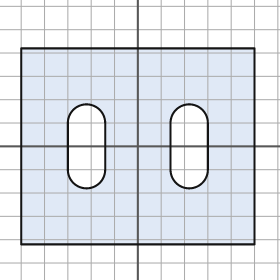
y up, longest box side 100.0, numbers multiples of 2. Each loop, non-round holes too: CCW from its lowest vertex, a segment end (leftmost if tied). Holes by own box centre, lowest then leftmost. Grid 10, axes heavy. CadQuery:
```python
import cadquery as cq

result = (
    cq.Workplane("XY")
    .moveTo(-50.0, -42.0)
    .lineTo(50.0, -42.0)
    .lineTo(50.0, 42.0)
    .lineTo(-50.0, 42.0)
    .close()
    .moveTo(-30.0, -10.0)
    .threePointArc((-22.0, -18.0), (-14.0, -10.0))
    .lineTo(-14.0, 10.0)
    .threePointArc((-22.0, 18.0), (-30.0, 10.0))
    .close()
    .moveTo(14.0, -10.0)
    .threePointArc((22.0, -18.0), (30.0, -10.0))
    .lineTo(30.0, 10.0)
    .threePointArc((22.0, 18.0), (14.0, 10.0))
    .close()
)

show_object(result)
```